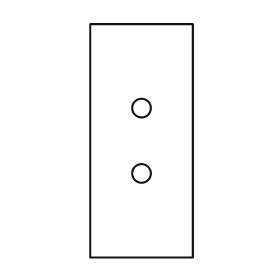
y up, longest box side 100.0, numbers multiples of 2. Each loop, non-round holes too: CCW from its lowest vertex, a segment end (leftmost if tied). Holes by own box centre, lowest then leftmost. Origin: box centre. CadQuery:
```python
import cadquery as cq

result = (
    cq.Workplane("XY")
    .moveTo(-22.0, -50.0)
    .lineTo(22.0, -50.0)
    .lineTo(22.0, 50.0)
    .lineTo(-22.0, 50.0)
    .close()
    .moveTo(0.0, -14.0)
    .circle(4.0)
    .moveTo(0.0, 14.0)
    .circle(4.0)
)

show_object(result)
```